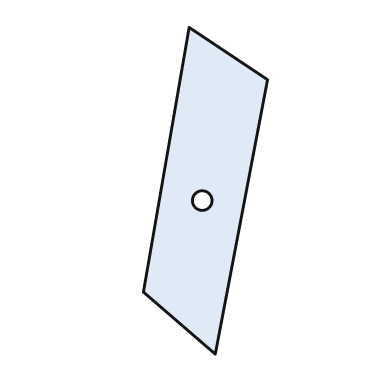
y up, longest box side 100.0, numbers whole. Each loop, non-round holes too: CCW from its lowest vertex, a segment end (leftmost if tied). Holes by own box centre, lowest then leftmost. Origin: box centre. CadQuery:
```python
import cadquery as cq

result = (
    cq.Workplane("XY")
    .moveTo(3.0, -50.0)
    .lineTo(19.0, 34.0)
    .lineTo(-5.0, 50.0)
    .lineTo(-19.0, -31.0)
    .close()
    .moveTo(-1.0, -3.0)
    .circle(3.0)
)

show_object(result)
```